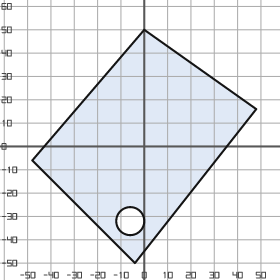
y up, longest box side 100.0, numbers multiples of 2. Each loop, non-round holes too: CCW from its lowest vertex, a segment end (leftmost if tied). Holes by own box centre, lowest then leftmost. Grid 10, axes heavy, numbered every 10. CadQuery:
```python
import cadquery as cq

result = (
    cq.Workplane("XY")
    .moveTo(-4.0, -50.0)
    .lineTo(48.0, 16.0)
    .lineTo(0.0, 50.0)
    .lineTo(-48.0, -6.0)
    .close()
    .moveTo(-6.0, -32.0)
    .circle(6.0)
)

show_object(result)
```